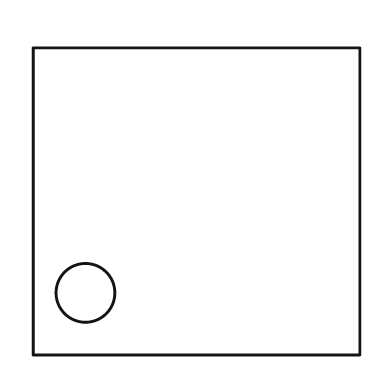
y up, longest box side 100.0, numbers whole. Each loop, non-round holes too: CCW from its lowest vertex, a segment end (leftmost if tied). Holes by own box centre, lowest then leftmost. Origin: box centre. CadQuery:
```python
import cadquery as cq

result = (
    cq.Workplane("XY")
    .moveTo(-50.0, -47.0)
    .lineTo(50.0, -47.0)
    .lineTo(50.0, 47.0)
    .lineTo(-50.0, 47.0)
    .close()
    .moveTo(-34.0, -28.0)
    .circle(9.0)
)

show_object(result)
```